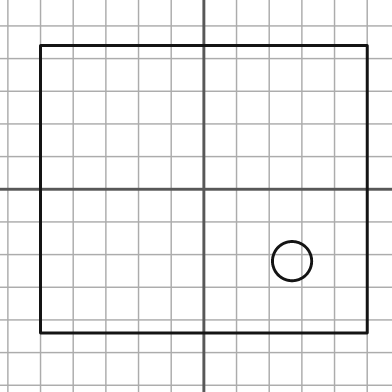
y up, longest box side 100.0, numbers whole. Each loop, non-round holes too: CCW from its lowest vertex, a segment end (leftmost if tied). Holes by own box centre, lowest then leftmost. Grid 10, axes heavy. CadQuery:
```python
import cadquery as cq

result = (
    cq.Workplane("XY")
    .moveTo(-50.0, -44.0)
    .lineTo(50.0, -44.0)
    .lineTo(50.0, 44.0)
    .lineTo(-50.0, 44.0)
    .close()
    .moveTo(27.0, -22.0)
    .circle(6.0)
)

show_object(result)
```